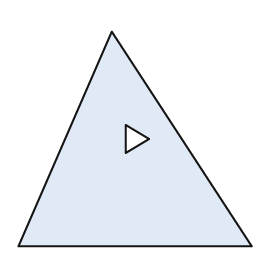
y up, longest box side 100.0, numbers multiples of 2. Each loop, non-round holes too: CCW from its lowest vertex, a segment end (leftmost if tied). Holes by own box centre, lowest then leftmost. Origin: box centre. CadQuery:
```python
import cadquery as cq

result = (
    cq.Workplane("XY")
    .moveTo(-50.0, -46.0)
    .lineTo(50.0, -46.0)
    .lineTo(-10.0, 46.0)
    .close()
    .moveTo(-4.0, -6.0)
    .lineTo(6.0, 0.0)
    .lineTo(-4.0, 6.0)
    .close()
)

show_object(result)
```